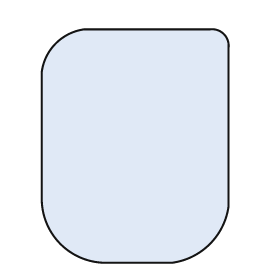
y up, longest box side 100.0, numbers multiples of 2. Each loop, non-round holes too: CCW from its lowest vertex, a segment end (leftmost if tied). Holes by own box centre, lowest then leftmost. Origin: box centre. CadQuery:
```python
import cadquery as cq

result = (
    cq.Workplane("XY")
    .moveTo(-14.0, -50.0)
    .lineTo(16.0, -50.0)
    .threePointArc((32.0, -42.0), (40.0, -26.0))
    .lineTo(40.0, 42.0)
    .threePointArc((38.0, 48.0), (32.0, 50.0))
    .lineTo(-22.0, 50.0)
    .threePointArc((-34.0, 44.0), (-40.0, 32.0))
    .lineTo(-40.0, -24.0)
    .threePointArc((-32.0, -42.0), (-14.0, -50.0))
    .close()
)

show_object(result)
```